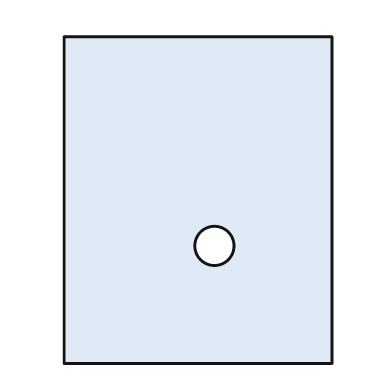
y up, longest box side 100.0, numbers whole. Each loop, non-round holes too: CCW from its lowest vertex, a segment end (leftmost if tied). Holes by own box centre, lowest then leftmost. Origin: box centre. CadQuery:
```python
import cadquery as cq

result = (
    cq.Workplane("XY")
    .moveTo(-41.0, -50.0)
    .lineTo(41.0, -50.0)
    .lineTo(41.0, 50.0)
    .lineTo(-41.0, 50.0)
    .close()
    .moveTo(5.0, -14.0)
    .circle(6.0)
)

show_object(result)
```